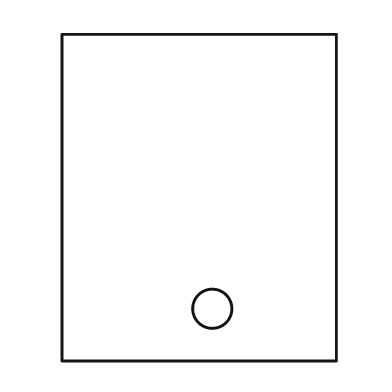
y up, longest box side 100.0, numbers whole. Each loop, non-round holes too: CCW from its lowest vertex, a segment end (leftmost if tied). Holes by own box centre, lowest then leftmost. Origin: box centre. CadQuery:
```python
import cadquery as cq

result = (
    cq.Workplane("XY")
    .moveTo(-42.0, -50.0)
    .lineTo(42.0, -50.0)
    .lineTo(42.0, 50.0)
    .lineTo(-42.0, 50.0)
    .close()
    .moveTo(4.0, -34.0)
    .circle(6.0)
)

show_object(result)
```